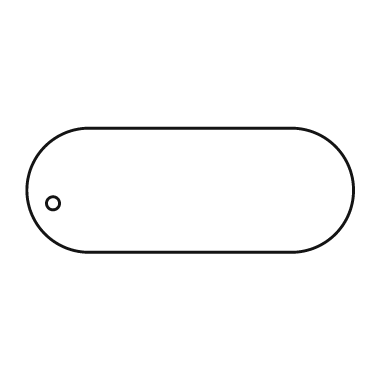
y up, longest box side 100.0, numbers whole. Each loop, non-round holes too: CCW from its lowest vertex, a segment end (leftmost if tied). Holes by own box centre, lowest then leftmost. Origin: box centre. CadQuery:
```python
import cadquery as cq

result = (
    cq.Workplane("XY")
    .moveTo(-31.0, -19.0)
    .lineTo(31.0, -19.0)
    .threePointArc((50.0, 0.0), (31.0, 19.0))
    .lineTo(-31.0, 19.0)
    .threePointArc((-50.0, 0.0), (-31.0, -19.0))
    .close()
    .moveTo(-42.0, -4.0)
    .circle(2.0)
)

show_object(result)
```